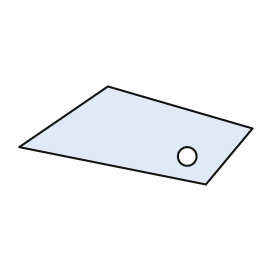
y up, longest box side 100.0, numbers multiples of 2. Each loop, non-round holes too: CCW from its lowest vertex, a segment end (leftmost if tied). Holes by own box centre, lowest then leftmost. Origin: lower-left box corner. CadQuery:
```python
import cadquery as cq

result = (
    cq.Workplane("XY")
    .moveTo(80.0, 0.0)
    .lineTo(100.0, 24.0)
    .lineTo(38.0, 42.0)
    .lineTo(0.0, 16.0)
    .close()
    .moveTo(72.0, 12.0)
    .circle(4.0)
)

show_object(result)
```